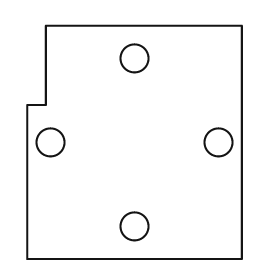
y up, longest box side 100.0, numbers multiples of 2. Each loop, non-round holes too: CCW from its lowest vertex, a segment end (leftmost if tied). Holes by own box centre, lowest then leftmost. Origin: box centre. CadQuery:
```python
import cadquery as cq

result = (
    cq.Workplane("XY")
    .moveTo(-46.0, -50.0)
    .lineTo(46.0, -50.0)
    .lineTo(46.0, 50.0)
    .lineTo(-38.0, 50.0)
    .lineTo(-38.0, 16.0)
    .lineTo(-46.0, 16.0)
    .close()
    .moveTo(0.0, -36.0)
    .circle(6.0)
    .moveTo(-36.0, 0.0)
    .circle(6.0)
    .moveTo(36.0, 0.0)
    .circle(6.0)
    .moveTo(0.0, 36.0)
    .circle(6.0)
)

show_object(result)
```